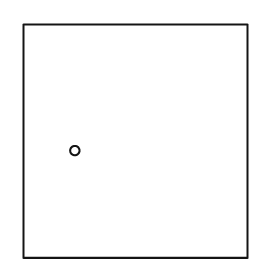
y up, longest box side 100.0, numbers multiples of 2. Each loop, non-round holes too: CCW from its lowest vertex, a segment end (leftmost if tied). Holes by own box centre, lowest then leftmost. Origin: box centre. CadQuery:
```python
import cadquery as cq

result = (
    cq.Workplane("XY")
    .moveTo(-48.0, -50.0)
    .lineTo(48.0, -50.0)
    .lineTo(48.0, 50.0)
    .lineTo(-48.0, 50.0)
    .close()
    .moveTo(-26.0, -4.0)
    .circle(2.0)
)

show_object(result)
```